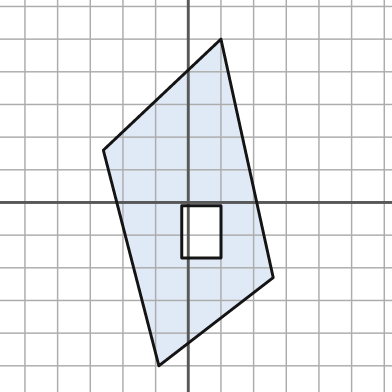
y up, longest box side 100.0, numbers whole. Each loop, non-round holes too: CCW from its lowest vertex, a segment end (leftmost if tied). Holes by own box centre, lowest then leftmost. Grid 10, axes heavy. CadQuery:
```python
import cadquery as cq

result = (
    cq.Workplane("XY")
    .moveTo(-9.0, -50.0)
    .lineTo(26.0, -23.0)
    .lineTo(10.0, 50.0)
    .lineTo(-26.0, 16.0)
    .close()
    .moveTo(-2.0, -17.0)
    .lineTo(10.0, -17.0)
    .lineTo(10.0, -1.0)
    .lineTo(-2.0, -1.0)
    .close()
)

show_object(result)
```